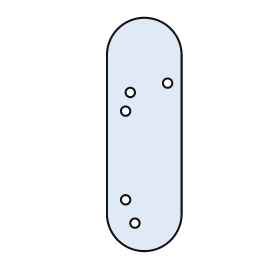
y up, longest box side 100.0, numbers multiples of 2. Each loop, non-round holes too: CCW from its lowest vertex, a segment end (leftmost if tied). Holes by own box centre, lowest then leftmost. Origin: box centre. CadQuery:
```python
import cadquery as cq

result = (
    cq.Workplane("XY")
    .moveTo(-16.0, -34.0)
    .threePointArc((0.0, -50.0), (16.0, -34.0))
    .lineTo(16.0, 34.0)
    .threePointArc((0.0, 50.0), (-16.0, 34.0))
    .close()
    .moveTo(-4.0, -38.0)
    .circle(2.0)
    .moveTo(-8.0, -28.0)
    .circle(2.0)
    .moveTo(-8.0, 10.0)
    .circle(2.0)
    .moveTo(-6.0, 18.0)
    .circle(2.0)
    .moveTo(10.0, 22.0)
    .circle(2.0)
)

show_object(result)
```